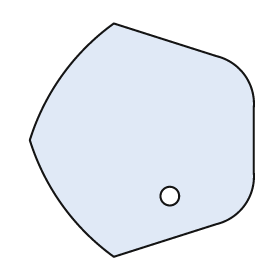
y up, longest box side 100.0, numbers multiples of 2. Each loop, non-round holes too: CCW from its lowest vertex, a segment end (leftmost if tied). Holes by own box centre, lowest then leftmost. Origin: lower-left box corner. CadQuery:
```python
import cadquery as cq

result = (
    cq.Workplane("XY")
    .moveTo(36.0, 0.0)
    .lineTo(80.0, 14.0)
    .threePointArc((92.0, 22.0), (96.0, 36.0))
    .lineTo(96.0, 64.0)
    .threePointArc((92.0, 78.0), (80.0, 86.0))
    .lineTo(36.0, 100.0)
    .threePointArc((14.0, 78.0), (0.0, 50.0))
    .threePointArc((14.0, 22.0), (36.0, 0.0))
    .close()
    .moveTo(60.0, 26.0)
    .circle(4.0)
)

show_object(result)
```